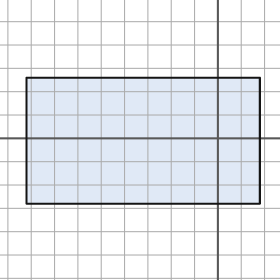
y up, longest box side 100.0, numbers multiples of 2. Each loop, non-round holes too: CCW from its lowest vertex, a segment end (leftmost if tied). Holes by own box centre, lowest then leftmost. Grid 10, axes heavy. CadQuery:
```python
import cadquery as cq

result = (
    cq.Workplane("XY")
    .moveTo(-82.0, -28.0)
    .lineTo(18.0, -28.0)
    .lineTo(18.0, 26.0)
    .lineTo(-82.0, 26.0)
    .close()
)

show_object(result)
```